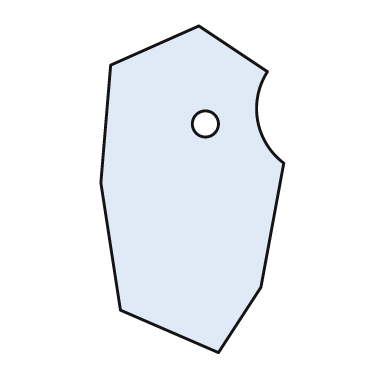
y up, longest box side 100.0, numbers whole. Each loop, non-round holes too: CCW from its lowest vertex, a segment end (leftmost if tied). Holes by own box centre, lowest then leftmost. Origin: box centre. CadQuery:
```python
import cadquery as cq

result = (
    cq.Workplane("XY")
    .moveTo(8.0, -50.0)
    .lineTo(21.0, -30.0)
    .lineTo(28.0, 8.0)
    .threePointArc((20.0, 21.0), (23.0, 36.0))
    .lineTo(2.0, 50.0)
    .lineTo(-25.0, 38.0)
    .lineTo(-28.0, 2.0)
    .lineTo(-22.0, -37.0)
    .close()
    .moveTo(4.0, 20.0)
    .circle(4.0)
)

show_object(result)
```